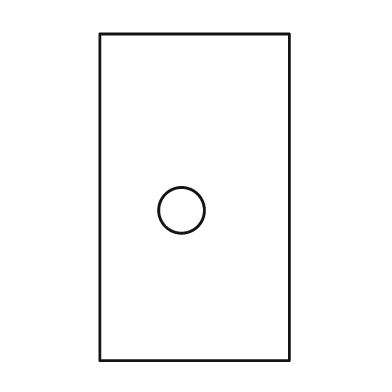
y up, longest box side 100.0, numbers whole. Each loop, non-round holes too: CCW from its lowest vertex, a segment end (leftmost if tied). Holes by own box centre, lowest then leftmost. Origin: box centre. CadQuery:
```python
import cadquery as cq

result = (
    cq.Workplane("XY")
    .moveTo(-29.0, -50.0)
    .lineTo(29.0, -50.0)
    .lineTo(29.0, 50.0)
    .lineTo(-29.0, 50.0)
    .close()
    .moveTo(-4.0, -4.0)
    .circle(7.0)
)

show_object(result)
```